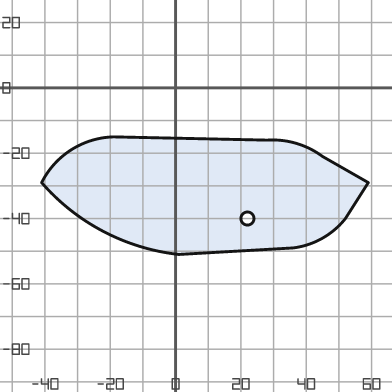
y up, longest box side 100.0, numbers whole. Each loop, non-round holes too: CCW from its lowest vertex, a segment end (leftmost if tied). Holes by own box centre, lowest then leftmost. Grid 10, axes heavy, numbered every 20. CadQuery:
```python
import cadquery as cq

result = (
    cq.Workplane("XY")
    .moveTo(1.0, -51.0)
    .lineTo(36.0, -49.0)
    .threePointArc((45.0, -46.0), (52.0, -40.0))
    .lineTo(59.0, -29.0)
    .lineTo(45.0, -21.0)
    .threePointArc((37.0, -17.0), (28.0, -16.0))
    .lineTo(-19.0, -15.0)
    .threePointArc((-32.0, -19.0), (-41.0, -29.0))
    .threePointArc((-22.0, -44.0), (1.0, -51.0))
    .close()
    .moveTo(22.0, -40.0)
    .circle(2.0)
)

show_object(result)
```